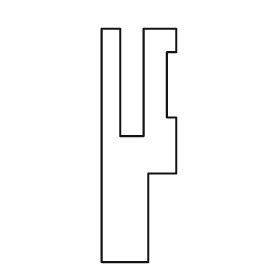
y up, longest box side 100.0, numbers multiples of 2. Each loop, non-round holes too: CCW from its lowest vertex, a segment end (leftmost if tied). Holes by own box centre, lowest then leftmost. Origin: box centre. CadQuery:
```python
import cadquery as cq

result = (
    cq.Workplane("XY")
    .moveTo(-16.0, -50.0)
    .lineTo(4.0, -50.0)
    .lineTo(4.0, -12.0)
    .lineTo(16.0, -12.0)
    .lineTo(16.0, 12.0)
    .lineTo(12.0, 12.0)
    .lineTo(12.0, 40.0)
    .lineTo(16.0, 40.0)
    .lineTo(16.0, 50.0)
    .lineTo(2.0, 50.0)
    .lineTo(2.0, 4.0)
    .lineTo(-8.0, 4.0)
    .lineTo(-8.0, 50.0)
    .lineTo(-16.0, 50.0)
    .close()
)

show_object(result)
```